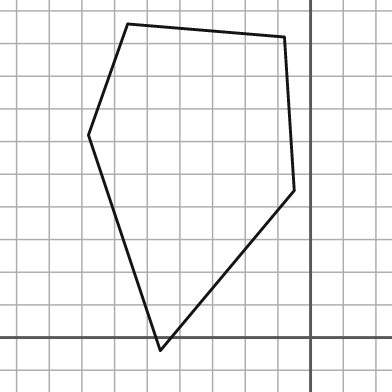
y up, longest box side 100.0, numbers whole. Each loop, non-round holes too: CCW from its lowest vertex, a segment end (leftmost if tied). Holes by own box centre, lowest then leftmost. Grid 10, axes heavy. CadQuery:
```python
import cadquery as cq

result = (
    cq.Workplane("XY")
    .moveTo(-46.0, -4.0)
    .lineTo(-5.0, 45.0)
    .lineTo(-8.0, 92.0)
    .lineTo(-56.0, 96.0)
    .lineTo(-68.0, 62.0)
    .close()
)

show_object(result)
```